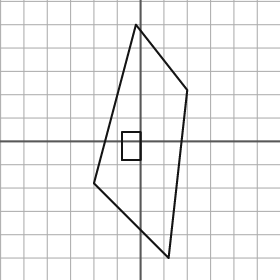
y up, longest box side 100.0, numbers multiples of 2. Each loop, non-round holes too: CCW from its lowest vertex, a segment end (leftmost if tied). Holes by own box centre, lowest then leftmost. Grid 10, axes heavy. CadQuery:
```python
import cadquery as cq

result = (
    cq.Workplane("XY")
    .moveTo(12.0, -50.0)
    .lineTo(20.0, 22.0)
    .lineTo(-2.0, 50.0)
    .lineTo(-20.0, -18.0)
    .close()
    .moveTo(-8.0, -8.0)
    .lineTo(0.0, -8.0)
    .lineTo(0.0, 4.0)
    .lineTo(-8.0, 4.0)
    .close()
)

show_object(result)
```